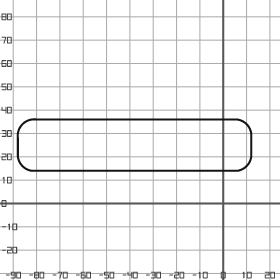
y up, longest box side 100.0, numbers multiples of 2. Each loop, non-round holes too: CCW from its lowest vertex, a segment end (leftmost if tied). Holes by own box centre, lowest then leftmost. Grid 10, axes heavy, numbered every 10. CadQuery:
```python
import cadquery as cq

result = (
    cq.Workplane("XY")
    .moveTo(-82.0, 14.0)
    .lineTo(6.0, 14.0)
    .threePointArc((10.0, 16.0), (12.0, 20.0))
    .lineTo(12.0, 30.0)
    .threePointArc((10.0, 34.0), (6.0, 36.0))
    .lineTo(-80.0, 36.0)
    .threePointArc((-86.0, 34.0), (-88.0, 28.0))
    .lineTo(-88.0, 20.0)
    .threePointArc((-86.0, 16.0), (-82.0, 14.0))
    .close()
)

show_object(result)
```